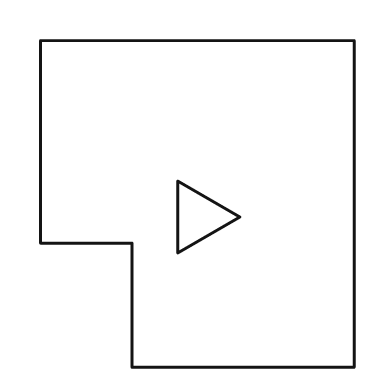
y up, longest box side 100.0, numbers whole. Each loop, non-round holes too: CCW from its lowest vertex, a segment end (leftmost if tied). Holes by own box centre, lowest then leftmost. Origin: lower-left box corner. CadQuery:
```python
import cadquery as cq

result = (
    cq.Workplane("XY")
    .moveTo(28.0, 0.0)
    .lineTo(96.0, 0.0)
    .lineTo(96.0, 100.0)
    .lineTo(0.0, 100.0)
    .lineTo(0.0, 38.0)
    .lineTo(28.0, 38.0)
    .close()
    .moveTo(42.0, 35.0)
    .lineTo(61.0, 46.0)
    .lineTo(42.0, 57.0)
    .close()
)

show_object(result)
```